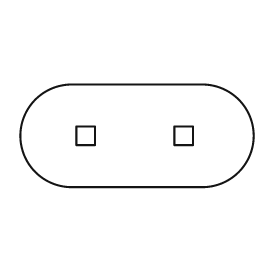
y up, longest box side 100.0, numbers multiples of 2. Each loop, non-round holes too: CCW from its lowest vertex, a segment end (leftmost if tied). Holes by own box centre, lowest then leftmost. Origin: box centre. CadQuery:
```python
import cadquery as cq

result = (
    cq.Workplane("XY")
    .moveTo(-28.0, -22.0)
    .lineTo(28.0, -22.0)
    .threePointArc((50.0, 0.0), (28.0, 22.0))
    .lineTo(-28.0, 22.0)
    .threePointArc((-50.0, 0.0), (-28.0, -22.0))
    .close()
    .moveTo(-26.0, -4.0)
    .lineTo(-18.0, -4.0)
    .lineTo(-18.0, 4.0)
    .lineTo(-26.0, 4.0)
    .close()
    .moveTo(16.0, -4.0)
    .lineTo(24.0, -4.0)
    .lineTo(24.0, 4.0)
    .lineTo(16.0, 4.0)
    .close()
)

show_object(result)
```